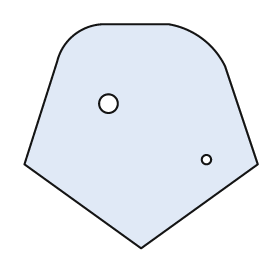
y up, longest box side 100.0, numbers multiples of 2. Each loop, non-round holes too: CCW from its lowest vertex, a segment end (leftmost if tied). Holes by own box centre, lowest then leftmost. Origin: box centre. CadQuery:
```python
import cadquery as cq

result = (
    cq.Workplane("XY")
    .moveTo(0.0, -48.0)
    .lineTo(50.0, -12.0)
    .lineTo(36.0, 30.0)
    .threePointArc((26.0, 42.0), (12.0, 48.0))
    .lineTo(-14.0, 48.0)
    .threePointArc((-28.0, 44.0), (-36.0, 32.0))
    .lineTo(-50.0, -12.0)
    .close()
    .moveTo(28.0, -10.0)
    .circle(2.0)
    .moveTo(-14.0, 14.0)
    .circle(4.0)
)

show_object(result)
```